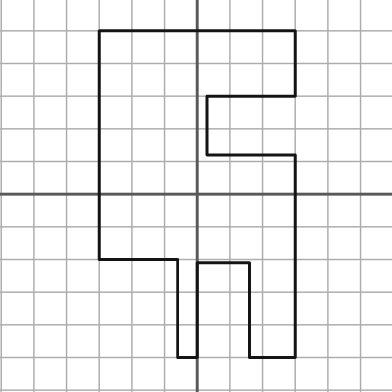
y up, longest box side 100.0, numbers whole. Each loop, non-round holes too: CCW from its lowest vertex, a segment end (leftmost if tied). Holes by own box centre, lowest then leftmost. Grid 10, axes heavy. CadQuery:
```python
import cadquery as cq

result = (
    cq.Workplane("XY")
    .moveTo(-6.0, -50.0)
    .lineTo(0.0, -50.0)
    .lineTo(0.0, -21.0)
    .lineTo(16.0, -21.0)
    .lineTo(16.0, -50.0)
    .lineTo(30.0, -50.0)
    .lineTo(30.0, 12.0)
    .lineTo(3.0, 12.0)
    .lineTo(3.0, 30.0)
    .lineTo(30.0, 30.0)
    .lineTo(30.0, 50.0)
    .lineTo(-30.0, 50.0)
    .lineTo(-30.0, -20.0)
    .lineTo(-6.0, -20.0)
    .close()
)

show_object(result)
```